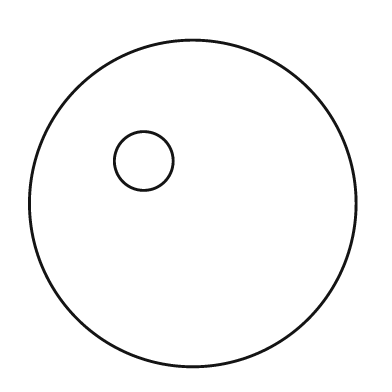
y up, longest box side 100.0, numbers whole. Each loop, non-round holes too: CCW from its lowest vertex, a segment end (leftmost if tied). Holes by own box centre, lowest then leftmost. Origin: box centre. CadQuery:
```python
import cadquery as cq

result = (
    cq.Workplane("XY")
    .moveTo(0.0, 0.0)
    .circle(50.0)
    .moveTo(-15.0, 13.0)
    .circle(9.0)
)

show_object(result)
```